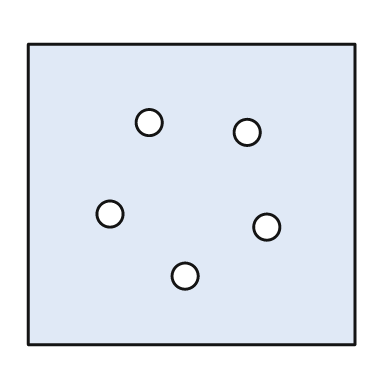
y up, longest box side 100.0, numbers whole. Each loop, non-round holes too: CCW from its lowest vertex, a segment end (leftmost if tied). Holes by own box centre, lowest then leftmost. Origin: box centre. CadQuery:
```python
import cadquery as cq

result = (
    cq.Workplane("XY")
    .moveTo(-50.0, -46.0)
    .lineTo(50.0, -46.0)
    .lineTo(50.0, 46.0)
    .lineTo(-50.0, 46.0)
    .close()
    .moveTo(-2.0, -25.0)
    .circle(4.0)
    .moveTo(23.0, -10.0)
    .circle(4.0)
    .moveTo(-25.0, -6.0)
    .circle(4.0)
    .moveTo(17.0, 19.0)
    .circle(4.0)
    .moveTo(-13.0, 22.0)
    .circle(4.0)
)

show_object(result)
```